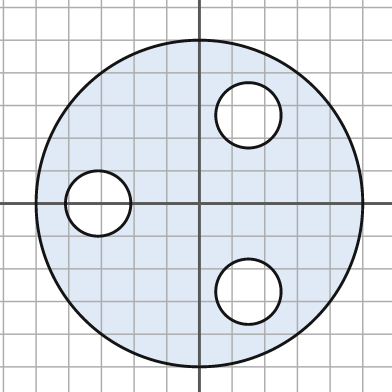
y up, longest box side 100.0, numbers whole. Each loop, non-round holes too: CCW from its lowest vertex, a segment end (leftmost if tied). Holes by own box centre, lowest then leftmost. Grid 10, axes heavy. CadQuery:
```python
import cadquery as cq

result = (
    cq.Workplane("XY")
    .moveTo(0.0, 0.0)
    .circle(50.0)
    .moveTo(15.0, -27.0)
    .circle(10.0)
    .moveTo(-31.0, 0.0)
    .circle(10.0)
    .moveTo(15.0, 27.0)
    .circle(10.0)
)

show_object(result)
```